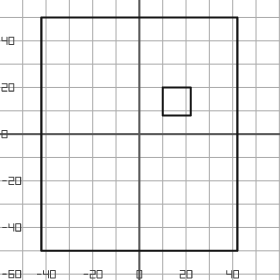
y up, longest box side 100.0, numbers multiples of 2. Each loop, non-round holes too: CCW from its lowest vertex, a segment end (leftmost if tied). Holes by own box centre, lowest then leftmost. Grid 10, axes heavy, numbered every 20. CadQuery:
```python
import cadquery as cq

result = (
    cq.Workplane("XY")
    .moveTo(-42.0, -50.0)
    .lineTo(42.0, -50.0)
    .lineTo(42.0, 50.0)
    .lineTo(-42.0, 50.0)
    .close()
    .moveTo(10.0, 8.0)
    .lineTo(22.0, 8.0)
    .lineTo(22.0, 20.0)
    .lineTo(10.0, 20.0)
    .close()
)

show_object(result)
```